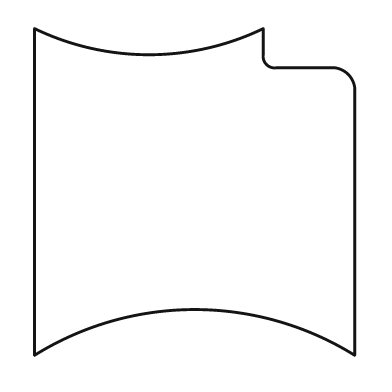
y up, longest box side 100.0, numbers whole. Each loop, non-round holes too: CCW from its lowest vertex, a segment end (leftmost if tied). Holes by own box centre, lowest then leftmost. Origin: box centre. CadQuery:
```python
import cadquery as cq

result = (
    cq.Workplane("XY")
    .moveTo(-49.0, -50.0)
    .threePointArc((0.0, -36.0), (49.0, -50.0))
    .lineTo(49.0, 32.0)
    .threePointArc((47.0, 36.0), (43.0, 38.0))
    .lineTo(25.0, 38.0)
    .threePointArc((22.0, 39.0), (21.0, 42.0))
    .lineTo(21.0, 50.0)
    .threePointArc((-14.0, 42.0), (-49.0, 50.0))
    .close()
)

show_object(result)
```